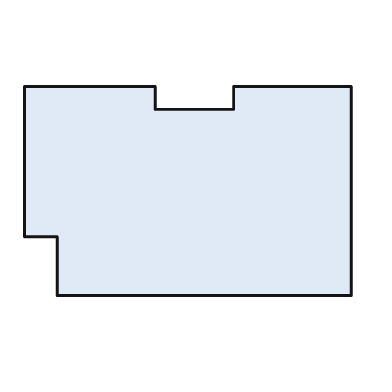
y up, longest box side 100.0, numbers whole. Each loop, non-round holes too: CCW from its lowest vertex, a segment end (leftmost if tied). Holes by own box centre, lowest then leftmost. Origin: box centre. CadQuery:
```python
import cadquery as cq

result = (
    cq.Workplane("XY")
    .moveTo(-40.0, -32.0)
    .lineTo(50.0, -32.0)
    .lineTo(50.0, 32.0)
    .lineTo(14.0, 32.0)
    .lineTo(14.0, 25.0)
    .lineTo(-10.0, 25.0)
    .lineTo(-10.0, 32.0)
    .lineTo(-50.0, 32.0)
    .lineTo(-50.0, -14.0)
    .lineTo(-40.0, -14.0)
    .close()
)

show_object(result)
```